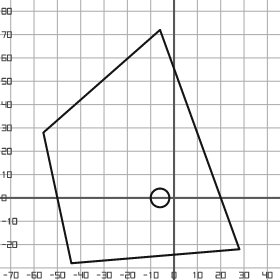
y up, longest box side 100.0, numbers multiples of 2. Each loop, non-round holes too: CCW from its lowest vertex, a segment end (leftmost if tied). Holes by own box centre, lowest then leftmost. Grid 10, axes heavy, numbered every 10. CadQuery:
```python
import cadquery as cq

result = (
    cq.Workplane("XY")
    .moveTo(-44.0, -28.0)
    .lineTo(28.0, -22.0)
    .lineTo(-6.0, 72.0)
    .lineTo(-56.0, 28.0)
    .close()
    .moveTo(-6.0, 0.0)
    .circle(4.0)
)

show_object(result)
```